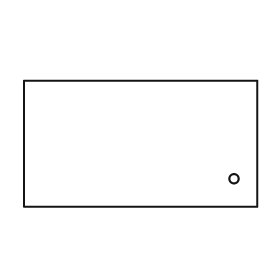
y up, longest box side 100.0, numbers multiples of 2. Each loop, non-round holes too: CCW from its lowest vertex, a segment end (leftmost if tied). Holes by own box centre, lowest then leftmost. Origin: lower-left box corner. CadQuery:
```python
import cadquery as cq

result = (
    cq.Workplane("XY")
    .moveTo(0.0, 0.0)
    .lineTo(100.0, 0.0)
    .lineTo(100.0, 54.0)
    .lineTo(0.0, 54.0)
    .close()
    .moveTo(90.0, 12.0)
    .circle(2.0)
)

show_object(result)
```